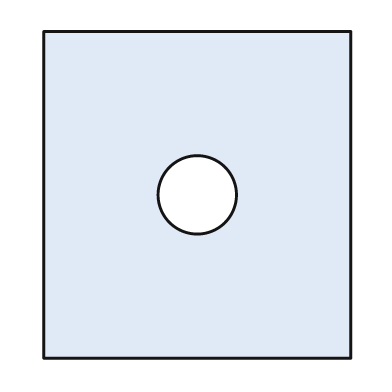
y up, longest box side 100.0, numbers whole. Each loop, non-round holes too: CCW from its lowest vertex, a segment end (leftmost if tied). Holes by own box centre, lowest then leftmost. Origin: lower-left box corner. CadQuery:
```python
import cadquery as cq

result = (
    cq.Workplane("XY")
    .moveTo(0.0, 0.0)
    .lineTo(94.0, 0.0)
    .lineTo(94.0, 100.0)
    .lineTo(0.0, 100.0)
    .close()
    .moveTo(47.0, 50.0)
    .circle(12.0)
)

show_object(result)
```